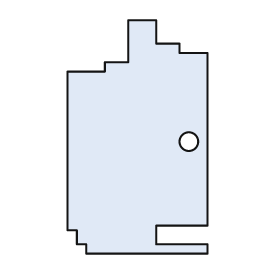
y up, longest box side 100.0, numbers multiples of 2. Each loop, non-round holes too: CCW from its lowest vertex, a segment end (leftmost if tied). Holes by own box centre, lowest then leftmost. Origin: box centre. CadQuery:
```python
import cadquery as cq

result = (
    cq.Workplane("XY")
    .moveTo(-22.0, -50.0)
    .lineTo(30.0, -50.0)
    .lineTo(30.0, -46.0)
    .lineTo(8.0, -46.0)
    .lineTo(8.0, -38.0)
    .lineTo(30.0, -38.0)
    .lineTo(30.0, 36.0)
    .lineTo(18.0, 36.0)
    .lineTo(18.0, 40.0)
    .lineTo(8.0, 40.0)
    .lineTo(8.0, 50.0)
    .lineTo(-4.0, 50.0)
    .lineTo(-4.0, 32.0)
    .lineTo(-14.0, 32.0)
    .lineTo(-14.0, 28.0)
    .lineTo(-30.0, 28.0)
    .lineTo(-30.0, -40.0)
    .lineTo(-26.0, -40.0)
    .lineTo(-26.0, -46.0)
    .lineTo(-22.0, -46.0)
    .close()
    .moveTo(22.0, -2.0)
    .circle(4.0)
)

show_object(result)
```